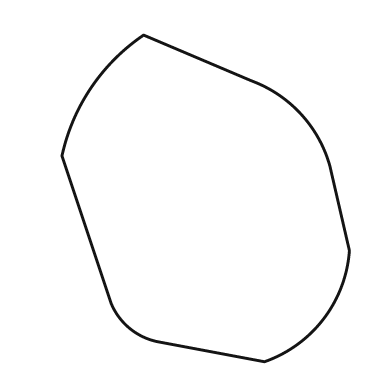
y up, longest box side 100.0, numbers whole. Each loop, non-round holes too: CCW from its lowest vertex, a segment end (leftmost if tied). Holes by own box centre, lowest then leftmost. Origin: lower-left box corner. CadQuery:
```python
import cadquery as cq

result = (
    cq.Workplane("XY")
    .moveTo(62.0, 0.0)
    .threePointArc((80.0, 13.0), (88.0, 34.0))
    .lineTo(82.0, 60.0)
    .threePointArc((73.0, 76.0), (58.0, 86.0))
    .lineTo(25.0, 100.0)
    .threePointArc((9.0, 84.0), (0.0, 63.0))
    .lineTo(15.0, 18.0)
    .threePointArc((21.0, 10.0), (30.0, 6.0))
    .close()
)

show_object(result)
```